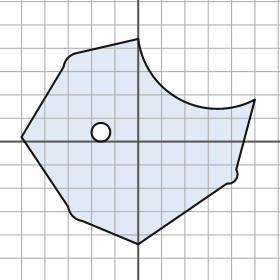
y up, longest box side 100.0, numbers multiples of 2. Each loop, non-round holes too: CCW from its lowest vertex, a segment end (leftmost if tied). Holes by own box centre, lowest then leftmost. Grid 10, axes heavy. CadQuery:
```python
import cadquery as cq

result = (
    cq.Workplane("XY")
    .moveTo(0.0, -44.0)
    .lineTo(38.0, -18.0)
    .threePointArc((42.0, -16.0), (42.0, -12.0))
    .lineTo(50.0, 18.0)
    .threePointArc((18.0, 18.0), (0.0, 44.0))
    .lineTo(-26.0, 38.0)
    .threePointArc((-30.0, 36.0), (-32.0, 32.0))
    .lineTo(-50.0, 2.0)
    .lineTo(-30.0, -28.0)
    .threePointArc((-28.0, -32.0), (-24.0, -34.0))
    .close()
    .moveTo(-16.0, 4.0)
    .circle(4.0)
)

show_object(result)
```